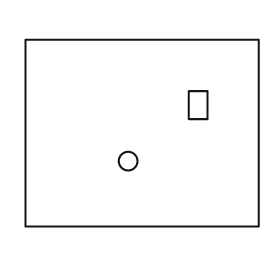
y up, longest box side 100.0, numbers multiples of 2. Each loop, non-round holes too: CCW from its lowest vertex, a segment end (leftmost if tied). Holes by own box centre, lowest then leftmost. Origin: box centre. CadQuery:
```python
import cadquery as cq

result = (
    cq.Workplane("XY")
    .moveTo(-50.0, -40.0)
    .lineTo(50.0, -40.0)
    .lineTo(50.0, 40.0)
    .lineTo(-50.0, 40.0)
    .close()
    .moveTo(-6.0, -12.0)
    .circle(4.0)
    .moveTo(20.0, 6.0)
    .lineTo(28.0, 6.0)
    .lineTo(28.0, 18.0)
    .lineTo(20.0, 18.0)
    .close()
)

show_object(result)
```